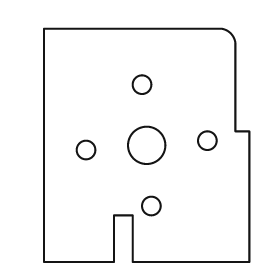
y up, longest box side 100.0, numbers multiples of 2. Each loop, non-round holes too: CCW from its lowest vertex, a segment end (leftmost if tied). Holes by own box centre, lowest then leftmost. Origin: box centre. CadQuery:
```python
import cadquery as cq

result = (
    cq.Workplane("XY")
    .moveTo(-44.0, -50.0)
    .lineTo(-14.0, -50.0)
    .lineTo(-14.0, -30.0)
    .lineTo(-6.0, -30.0)
    .lineTo(-6.0, -50.0)
    .lineTo(44.0, -50.0)
    .lineTo(44.0, 6.0)
    .lineTo(38.0, 6.0)
    .lineTo(38.0, 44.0)
    .threePointArc((36.0, 48.0), (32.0, 50.0))
    .lineTo(-44.0, 50.0)
    .close()
    .moveTo(2.0, -26.0)
    .circle(4.0)
    .moveTo(-26.0, -2.0)
    .circle(4.0)
    .moveTo(0.0, 0.0)
    .circle(8.0)
    .moveTo(26.0, 2.0)
    .circle(4.0)
    .moveTo(-2.0, 26.0)
    .circle(4.0)
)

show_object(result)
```